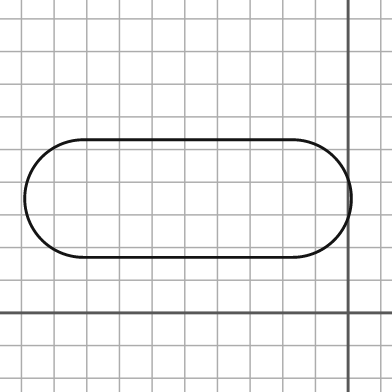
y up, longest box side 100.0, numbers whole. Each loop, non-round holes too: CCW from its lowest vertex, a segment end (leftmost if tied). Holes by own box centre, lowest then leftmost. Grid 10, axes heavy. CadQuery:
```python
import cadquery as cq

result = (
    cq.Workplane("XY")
    .moveTo(-81.0, 17.0)
    .lineTo(-17.0, 17.0)
    .threePointArc((1.0, 35.0), (-17.0, 53.0))
    .lineTo(-81.0, 53.0)
    .threePointArc((-99.0, 35.0), (-81.0, 17.0))
    .close()
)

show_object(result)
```